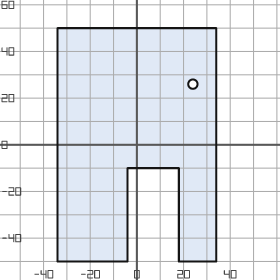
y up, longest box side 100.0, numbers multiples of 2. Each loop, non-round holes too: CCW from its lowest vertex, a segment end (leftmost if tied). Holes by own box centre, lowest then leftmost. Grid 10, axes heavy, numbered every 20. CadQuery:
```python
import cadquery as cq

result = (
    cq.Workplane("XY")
    .moveTo(-34.0, -50.0)
    .lineTo(-4.0, -50.0)
    .lineTo(-4.0, -10.0)
    .lineTo(18.0, -10.0)
    .lineTo(18.0, -50.0)
    .lineTo(34.0, -50.0)
    .lineTo(34.0, 50.0)
    .lineTo(-34.0, 50.0)
    .close()
    .moveTo(24.0, 26.0)
    .circle(2.0)
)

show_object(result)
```